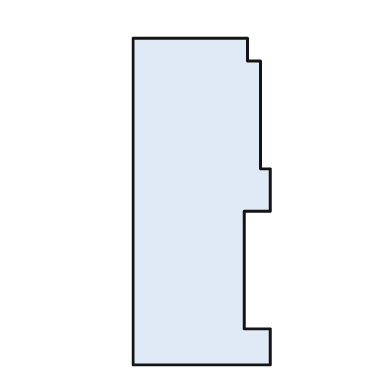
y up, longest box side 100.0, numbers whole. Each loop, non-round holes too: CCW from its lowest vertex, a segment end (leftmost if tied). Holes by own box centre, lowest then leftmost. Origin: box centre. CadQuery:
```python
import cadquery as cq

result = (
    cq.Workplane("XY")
    .moveTo(-21.0, -50.0)
    .lineTo(21.0, -50.0)
    .lineTo(21.0, -39.0)
    .lineTo(13.0, -39.0)
    .lineTo(13.0, -3.0)
    .lineTo(21.0, -3.0)
    .lineTo(21.0, 10.0)
    .lineTo(18.0, 10.0)
    .lineTo(18.0, 43.0)
    .lineTo(14.0, 43.0)
    .lineTo(14.0, 50.0)
    .lineTo(-21.0, 50.0)
    .close()
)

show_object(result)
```